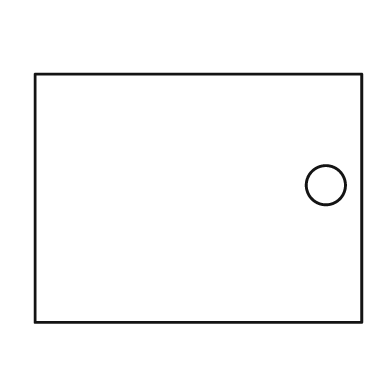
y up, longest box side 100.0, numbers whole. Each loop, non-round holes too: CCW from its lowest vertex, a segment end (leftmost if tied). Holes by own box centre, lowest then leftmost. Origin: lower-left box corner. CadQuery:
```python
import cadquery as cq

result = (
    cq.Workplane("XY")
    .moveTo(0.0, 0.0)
    .lineTo(100.0, 0.0)
    .lineTo(100.0, 76.0)
    .lineTo(0.0, 76.0)
    .close()
    .moveTo(89.0, 42.0)
    .circle(6.0)
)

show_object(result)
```